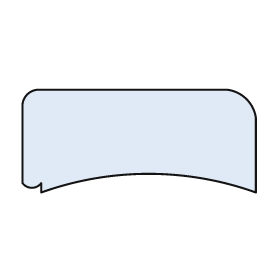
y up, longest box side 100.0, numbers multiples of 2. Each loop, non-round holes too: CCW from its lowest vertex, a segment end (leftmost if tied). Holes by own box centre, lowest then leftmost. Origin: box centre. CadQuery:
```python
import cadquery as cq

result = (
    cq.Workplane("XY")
    .moveTo(-42.0, -22.0)
    .threePointArc((4.0, -14.0), (50.0, -22.0))
    .lineTo(50.0, 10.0)
    .threePointArc((46.0, 18.0), (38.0, 22.0))
    .lineTo(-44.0, 22.0)
    .threePointArc((-48.0, 20.0), (-50.0, 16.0))
    .lineTo(-50.0, -18.0)
    .threePointArc((-46.0, -20.0), (-42.0, -18.0))
    .close()
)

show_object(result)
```